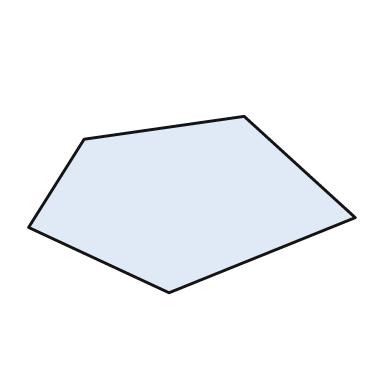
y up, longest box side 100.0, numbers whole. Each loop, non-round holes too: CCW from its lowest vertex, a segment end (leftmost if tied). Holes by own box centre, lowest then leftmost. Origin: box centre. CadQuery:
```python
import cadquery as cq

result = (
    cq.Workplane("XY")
    .moveTo(-7.0, -27.0)
    .lineTo(50.0, -4.0)
    .lineTo(16.0, 27.0)
    .lineTo(-33.0, 20.0)
    .lineTo(-50.0, -7.0)
    .close()
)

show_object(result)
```